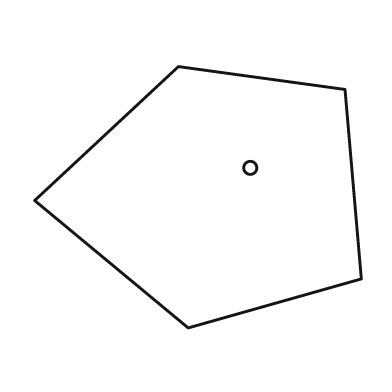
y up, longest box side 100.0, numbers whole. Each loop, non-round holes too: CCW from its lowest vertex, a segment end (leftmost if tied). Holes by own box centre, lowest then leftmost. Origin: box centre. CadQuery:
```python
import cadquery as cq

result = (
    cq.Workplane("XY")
    .moveTo(-3.0, -40.0)
    .lineTo(50.0, -25.0)
    .lineTo(45.0, 33.0)
    .lineTo(-6.0, 40.0)
    .lineTo(-50.0, -1.0)
    .close()
    .moveTo(16.0, 9.0)
    .circle(2.0)
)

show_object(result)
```